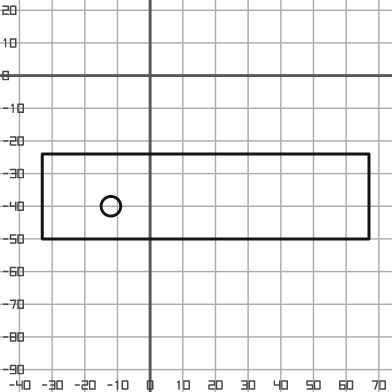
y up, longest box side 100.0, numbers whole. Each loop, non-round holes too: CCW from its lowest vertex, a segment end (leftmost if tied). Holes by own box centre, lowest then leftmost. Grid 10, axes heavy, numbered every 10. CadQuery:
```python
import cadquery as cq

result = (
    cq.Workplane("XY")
    .moveTo(-33.0, -50.0)
    .lineTo(67.0, -50.0)
    .lineTo(67.0, -24.0)
    .lineTo(-33.0, -24.0)
    .close()
    .moveTo(-12.0, -40.0)
    .circle(3.0)
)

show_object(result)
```